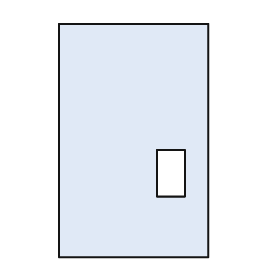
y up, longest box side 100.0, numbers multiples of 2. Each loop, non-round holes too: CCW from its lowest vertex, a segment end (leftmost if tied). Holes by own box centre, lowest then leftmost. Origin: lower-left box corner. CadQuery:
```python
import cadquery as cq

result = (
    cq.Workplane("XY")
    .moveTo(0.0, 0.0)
    .lineTo(64.0, 0.0)
    .lineTo(64.0, 100.0)
    .lineTo(0.0, 100.0)
    .close()
    .moveTo(42.0, 26.0)
    .lineTo(54.0, 26.0)
    .lineTo(54.0, 46.0)
    .lineTo(42.0, 46.0)
    .close()
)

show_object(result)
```